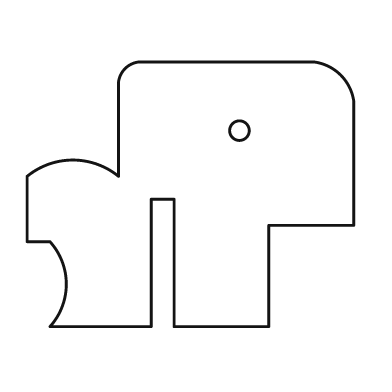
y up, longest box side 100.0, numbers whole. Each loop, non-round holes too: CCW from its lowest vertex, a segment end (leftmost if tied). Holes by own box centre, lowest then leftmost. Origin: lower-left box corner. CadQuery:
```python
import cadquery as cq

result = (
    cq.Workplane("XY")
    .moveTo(7.0, 0.0)
    .lineTo(38.0, 0.0)
    .lineTo(38.0, 39.0)
    .lineTo(45.0, 39.0)
    .lineTo(45.0, 0.0)
    .lineTo(74.0, 0.0)
    .lineTo(74.0, 31.0)
    .lineTo(100.0, 31.0)
    .lineTo(100.0, 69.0)
    .threePointArc((96.0, 77.0), (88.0, 81.0))
    .lineTo(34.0, 81.0)
    .threePointArc((30.0, 79.0), (28.0, 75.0))
    .lineTo(28.0, 46.0)
    .threePointArc((14.0, 51.0), (0.0, 46.0))
    .lineTo(0.0, 26.0)
    .lineTo(7.0, 26.0)
    .threePointArc((12.0, 13.0), (7.0, 0.0))
    .close()
    .moveTo(65.0, 60.0)
    .circle(3.0)
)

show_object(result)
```